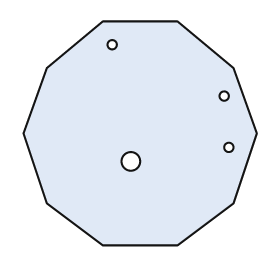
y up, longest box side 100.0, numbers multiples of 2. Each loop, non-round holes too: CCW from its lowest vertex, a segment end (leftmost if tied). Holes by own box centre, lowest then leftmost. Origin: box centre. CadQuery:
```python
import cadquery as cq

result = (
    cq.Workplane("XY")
    .moveTo(-16.0, -48.0)
    .lineTo(16.0, -48.0)
    .lineTo(40.0, -30.0)
    .lineTo(50.0, 0.0)
    .lineTo(40.0, 28.0)
    .lineTo(16.0, 48.0)
    .lineTo(-16.0, 48.0)
    .lineTo(-40.0, 28.0)
    .lineTo(-50.0, 0.0)
    .lineTo(-40.0, -30.0)
    .close()
    .moveTo(-4.0, -12.0)
    .circle(4.0)
    .moveTo(38.0, -6.0)
    .circle(2.0)
    .moveTo(36.0, 16.0)
    .circle(2.0)
    .moveTo(-12.0, 38.0)
    .circle(2.0)
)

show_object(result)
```